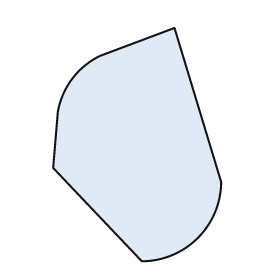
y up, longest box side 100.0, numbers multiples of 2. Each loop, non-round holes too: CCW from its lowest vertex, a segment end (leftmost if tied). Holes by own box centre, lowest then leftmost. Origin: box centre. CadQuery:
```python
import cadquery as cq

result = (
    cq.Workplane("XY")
    .moveTo(2.0, -50.0)
    .threePointArc((26.0, -40.0), (36.0, -16.0))
    .lineTo(16.0, 50.0)
    .lineTo(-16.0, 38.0)
    .threePointArc((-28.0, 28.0), (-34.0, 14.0))
    .lineTo(-36.0, -10.0)
    .close()
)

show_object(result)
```